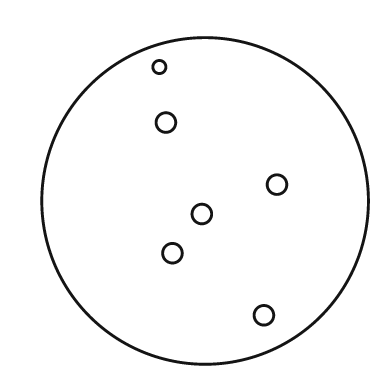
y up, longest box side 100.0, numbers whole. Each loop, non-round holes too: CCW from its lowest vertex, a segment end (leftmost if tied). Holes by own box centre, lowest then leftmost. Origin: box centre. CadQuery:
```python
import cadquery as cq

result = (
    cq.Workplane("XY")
    .moveTo(0.0, 0.0)
    .circle(50.0)
    .moveTo(18.0, -35.0)
    .circle(3.0)
    .moveTo(-10.0, -16.0)
    .circle(3.0)
    .moveTo(-1.0, -4.0)
    .circle(3.0)
    .moveTo(22.0, 5.0)
    .circle(3.0)
    .moveTo(-12.0, 24.0)
    .circle(3.0)
    .moveTo(-14.0, 41.0)
    .circle(2.0)
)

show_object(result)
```